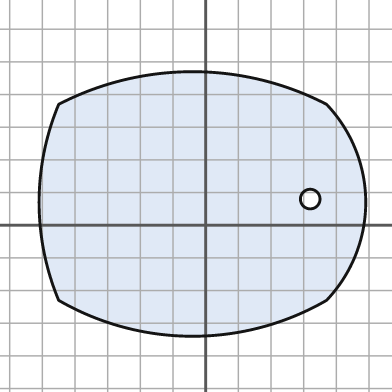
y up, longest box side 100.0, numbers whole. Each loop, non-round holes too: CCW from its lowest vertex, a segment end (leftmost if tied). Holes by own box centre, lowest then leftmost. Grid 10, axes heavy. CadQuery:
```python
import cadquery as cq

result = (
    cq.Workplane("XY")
    .moveTo(-45.0, -23.0)
    .threePointArc((-4.0, -34.0), (37.0, -23.0))
    .threePointArc((49.0, 7.0), (37.0, 37.0))
    .threePointArc((-4.0, 47.0), (-45.0, 37.0))
    .threePointArc((-51.0, 7.0), (-45.0, -23.0))
    .close()
    .moveTo(32.0, 8.0)
    .circle(3.0)
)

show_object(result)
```